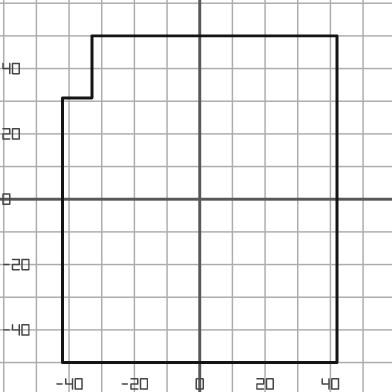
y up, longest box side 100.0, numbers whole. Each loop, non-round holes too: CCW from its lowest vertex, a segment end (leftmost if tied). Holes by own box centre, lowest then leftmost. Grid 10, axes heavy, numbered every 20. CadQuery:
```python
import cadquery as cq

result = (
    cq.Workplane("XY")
    .moveTo(-42.0, -50.0)
    .lineTo(42.0, -50.0)
    .lineTo(42.0, 50.0)
    .lineTo(-33.0, 50.0)
    .lineTo(-33.0, 31.0)
    .lineTo(-42.0, 31.0)
    .close()
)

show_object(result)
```